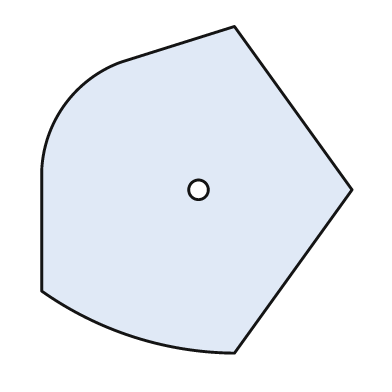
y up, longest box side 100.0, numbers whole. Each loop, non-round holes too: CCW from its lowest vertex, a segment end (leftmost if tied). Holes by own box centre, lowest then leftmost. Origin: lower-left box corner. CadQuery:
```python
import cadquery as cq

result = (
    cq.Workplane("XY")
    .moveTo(59.0, 0.0)
    .lineTo(95.0, 50.0)
    .lineTo(59.0, 100.0)
    .lineTo(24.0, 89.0)
    .threePointArc((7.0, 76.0), (0.0, 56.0))
    .lineTo(0.0, 19.0)
    .threePointArc((28.0, 5.0), (59.0, 0.0))
    .close()
    .moveTo(48.0, 50.0)
    .circle(3.0)
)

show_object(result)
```